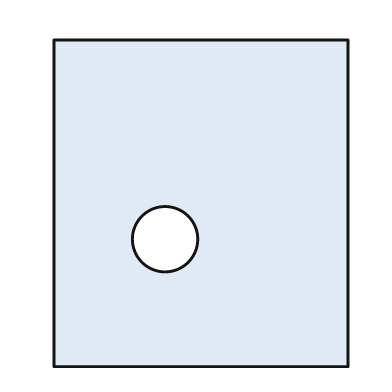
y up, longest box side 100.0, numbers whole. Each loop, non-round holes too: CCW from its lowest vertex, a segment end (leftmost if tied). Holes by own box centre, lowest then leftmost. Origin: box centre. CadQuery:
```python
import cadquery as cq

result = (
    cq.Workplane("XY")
    .moveTo(-45.0, -50.0)
    .lineTo(45.0, -50.0)
    .lineTo(45.0, 50.0)
    .lineTo(-45.0, 50.0)
    .close()
    .moveTo(-11.0, -11.0)
    .circle(10.0)
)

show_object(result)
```